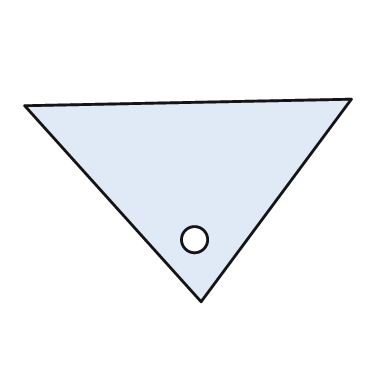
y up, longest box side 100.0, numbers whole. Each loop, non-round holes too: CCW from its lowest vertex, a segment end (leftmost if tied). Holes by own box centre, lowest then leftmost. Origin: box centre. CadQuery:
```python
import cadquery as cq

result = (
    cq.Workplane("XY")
    .moveTo(4.0, -31.0)
    .lineTo(50.0, 31.0)
    .lineTo(-50.0, 29.0)
    .close()
    .moveTo(2.0, -12.0)
    .circle(4.0)
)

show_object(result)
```